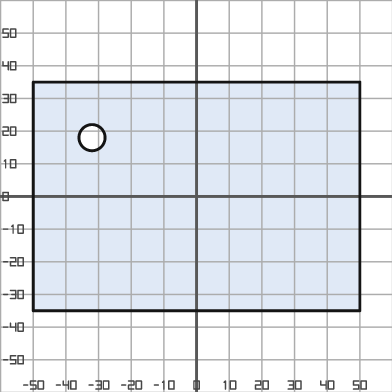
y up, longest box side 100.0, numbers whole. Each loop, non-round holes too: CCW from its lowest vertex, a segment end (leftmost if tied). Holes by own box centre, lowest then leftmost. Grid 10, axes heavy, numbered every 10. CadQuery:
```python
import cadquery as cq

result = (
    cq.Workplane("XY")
    .moveTo(-50.0, -35.0)
    .lineTo(50.0, -35.0)
    .lineTo(50.0, 35.0)
    .lineTo(-50.0, 35.0)
    .close()
    .moveTo(-32.0, 18.0)
    .circle(4.0)
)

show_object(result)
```